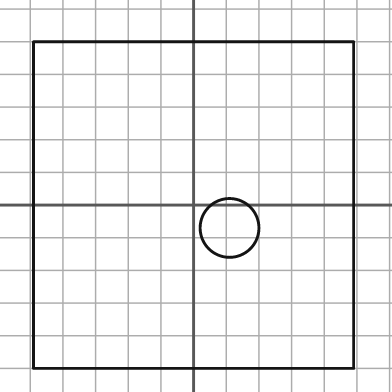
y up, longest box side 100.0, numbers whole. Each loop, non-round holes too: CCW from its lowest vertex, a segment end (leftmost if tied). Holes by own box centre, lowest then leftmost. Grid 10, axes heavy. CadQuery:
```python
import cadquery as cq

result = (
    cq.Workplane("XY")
    .moveTo(-49.0, -50.0)
    .lineTo(49.0, -50.0)
    .lineTo(49.0, 50.0)
    .lineTo(-49.0, 50.0)
    .close()
    .moveTo(11.0, -7.0)
    .circle(9.0)
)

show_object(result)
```